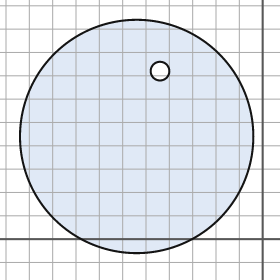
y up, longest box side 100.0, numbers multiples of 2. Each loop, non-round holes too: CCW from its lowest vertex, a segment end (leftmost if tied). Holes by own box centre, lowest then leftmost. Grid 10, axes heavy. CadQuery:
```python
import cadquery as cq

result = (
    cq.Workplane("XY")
    .moveTo(-54.0, 44.0)
    .circle(50.0)
    .moveTo(-44.0, 72.0)
    .circle(4.0)
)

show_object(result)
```